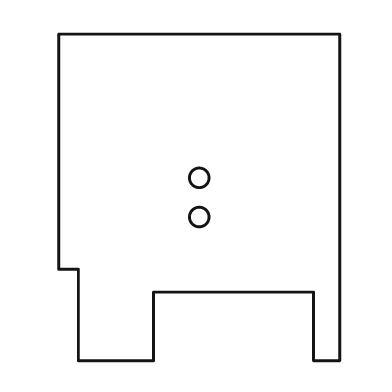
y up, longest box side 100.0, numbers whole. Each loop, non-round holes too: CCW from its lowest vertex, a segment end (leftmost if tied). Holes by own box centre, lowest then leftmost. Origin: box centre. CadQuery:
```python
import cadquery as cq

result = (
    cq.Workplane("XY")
    .moveTo(-37.0, -50.0)
    .lineTo(-14.0, -50.0)
    .lineTo(-14.0, -29.0)
    .lineTo(35.0, -29.0)
    .lineTo(35.0, -50.0)
    .lineTo(43.0, -50.0)
    .lineTo(43.0, 50.0)
    .lineTo(-43.0, 50.0)
    .lineTo(-43.0, -22.0)
    .lineTo(-37.0, -22.0)
    .close()
    .moveTo(0.0, -6.0)
    .circle(3.0)
    .moveTo(0.0, 6.0)
    .circle(3.0)
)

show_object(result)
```